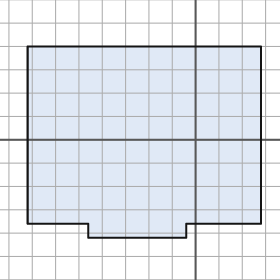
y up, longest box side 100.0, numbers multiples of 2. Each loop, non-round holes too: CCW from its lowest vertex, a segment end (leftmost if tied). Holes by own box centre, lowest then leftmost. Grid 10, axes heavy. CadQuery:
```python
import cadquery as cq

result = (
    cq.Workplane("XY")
    .moveTo(-46.0, -42.0)
    .lineTo(-4.0, -42.0)
    .lineTo(-4.0, -36.0)
    .lineTo(28.0, -36.0)
    .lineTo(28.0, 40.0)
    .lineTo(-72.0, 40.0)
    .lineTo(-72.0, -36.0)
    .lineTo(-46.0, -36.0)
    .close()
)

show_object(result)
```